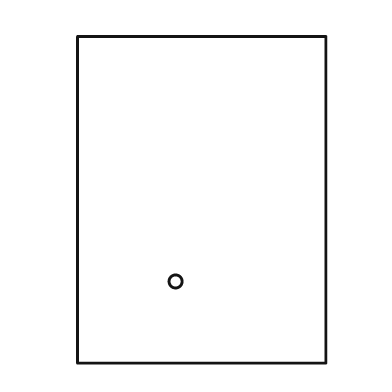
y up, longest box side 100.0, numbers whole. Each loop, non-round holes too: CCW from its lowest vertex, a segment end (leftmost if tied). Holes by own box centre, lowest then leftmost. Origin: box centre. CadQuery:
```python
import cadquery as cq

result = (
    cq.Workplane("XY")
    .moveTo(-38.0, -50.0)
    .lineTo(38.0, -50.0)
    .lineTo(38.0, 50.0)
    .lineTo(-38.0, 50.0)
    .close()
    .moveTo(-8.0, -25.0)
    .circle(2.0)
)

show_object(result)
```